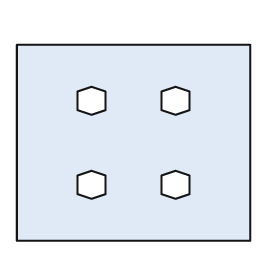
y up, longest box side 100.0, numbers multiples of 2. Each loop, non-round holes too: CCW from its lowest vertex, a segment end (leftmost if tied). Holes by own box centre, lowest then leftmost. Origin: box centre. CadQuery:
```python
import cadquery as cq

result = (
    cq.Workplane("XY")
    .moveTo(-50.0, -42.0)
    .lineTo(50.0, -42.0)
    .lineTo(50.0, 42.0)
    .lineTo(-50.0, 42.0)
    .close()
    .moveTo(-18.0, -24.0)
    .lineTo(-12.0, -22.0)
    .lineTo(-12.0, -14.0)
    .lineTo(-18.0, -12.0)
    .lineTo(-24.0, -14.0)
    .lineTo(-24.0, -22.0)
    .close()
    .moveTo(18.0, -24.0)
    .lineTo(24.0, -22.0)
    .lineTo(24.0, -14.0)
    .lineTo(18.0, -12.0)
    .lineTo(12.0, -14.0)
    .lineTo(12.0, -22.0)
    .close()
    .moveTo(-18.0, 12.0)
    .lineTo(-12.0, 14.0)
    .lineTo(-12.0, 22.0)
    .lineTo(-18.0, 24.0)
    .lineTo(-24.0, 22.0)
    .lineTo(-24.0, 14.0)
    .close()
    .moveTo(18.0, 12.0)
    .lineTo(24.0, 14.0)
    .lineTo(24.0, 22.0)
    .lineTo(18.0, 24.0)
    .lineTo(12.0, 22.0)
    .lineTo(12.0, 14.0)
    .close()
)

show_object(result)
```